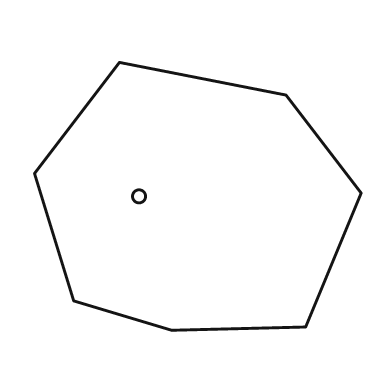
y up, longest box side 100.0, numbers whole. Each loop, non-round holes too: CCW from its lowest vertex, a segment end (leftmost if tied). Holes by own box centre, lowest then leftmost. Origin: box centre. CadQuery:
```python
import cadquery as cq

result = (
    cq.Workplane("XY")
    .moveTo(-8.0, -41.0)
    .lineTo(33.0, -40.0)
    .lineTo(50.0, 1.0)
    .lineTo(27.0, 31.0)
    .lineTo(-24.0, 41.0)
    .lineTo(-50.0, 7.0)
    .lineTo(-38.0, -32.0)
    .close()
    .moveTo(-18.0, 0.0)
    .circle(2.0)
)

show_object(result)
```